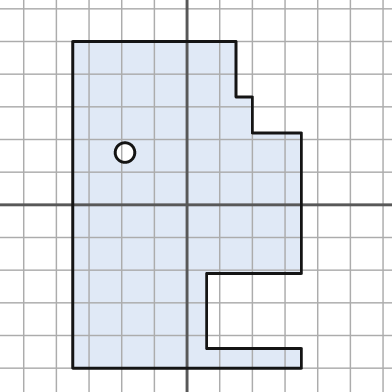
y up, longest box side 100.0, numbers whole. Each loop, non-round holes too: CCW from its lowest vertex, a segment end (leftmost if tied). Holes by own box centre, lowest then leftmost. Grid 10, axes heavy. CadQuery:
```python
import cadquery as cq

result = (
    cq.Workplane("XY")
    .moveTo(-35.0, -50.0)
    .lineTo(35.0, -50.0)
    .lineTo(35.0, -44.0)
    .lineTo(6.0, -44.0)
    .lineTo(6.0, -21.0)
    .lineTo(35.0, -21.0)
    .lineTo(35.0, 22.0)
    .lineTo(20.0, 22.0)
    .lineTo(20.0, 33.0)
    .lineTo(15.0, 33.0)
    .lineTo(15.0, 50.0)
    .lineTo(-35.0, 50.0)
    .close()
    .moveTo(-19.0, 16.0)
    .circle(3.0)
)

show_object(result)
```